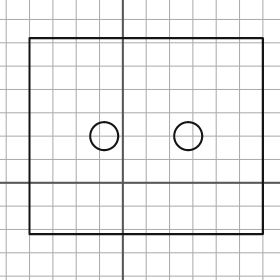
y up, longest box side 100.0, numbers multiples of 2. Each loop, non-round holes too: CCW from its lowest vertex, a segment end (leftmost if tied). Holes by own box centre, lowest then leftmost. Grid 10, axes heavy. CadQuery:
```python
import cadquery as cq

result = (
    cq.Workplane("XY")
    .moveTo(-40.0, -22.0)
    .lineTo(60.0, -22.0)
    .lineTo(60.0, 62.0)
    .lineTo(-40.0, 62.0)
    .close()
    .moveTo(-8.0, 20.0)
    .circle(6.0)
    .moveTo(28.0, 20.0)
    .circle(6.0)
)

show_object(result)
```